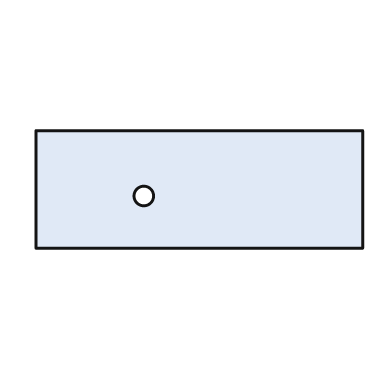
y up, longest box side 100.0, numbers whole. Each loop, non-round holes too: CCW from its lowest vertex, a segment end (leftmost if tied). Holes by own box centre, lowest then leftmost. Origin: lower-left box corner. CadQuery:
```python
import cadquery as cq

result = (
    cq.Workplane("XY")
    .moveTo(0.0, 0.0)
    .lineTo(100.0, 0.0)
    .lineTo(100.0, 36.0)
    .lineTo(0.0, 36.0)
    .close()
    .moveTo(33.0, 16.0)
    .circle(3.0)
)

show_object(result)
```